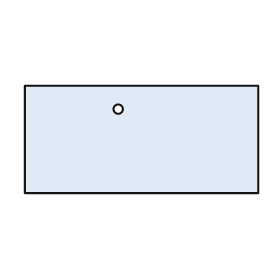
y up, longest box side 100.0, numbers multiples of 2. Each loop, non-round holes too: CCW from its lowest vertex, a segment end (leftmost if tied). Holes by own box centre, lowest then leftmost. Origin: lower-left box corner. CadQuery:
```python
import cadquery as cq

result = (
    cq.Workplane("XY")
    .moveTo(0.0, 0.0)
    .lineTo(100.0, 0.0)
    .lineTo(100.0, 46.0)
    .lineTo(0.0, 46.0)
    .close()
    .moveTo(40.0, 36.0)
    .circle(2.0)
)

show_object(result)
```